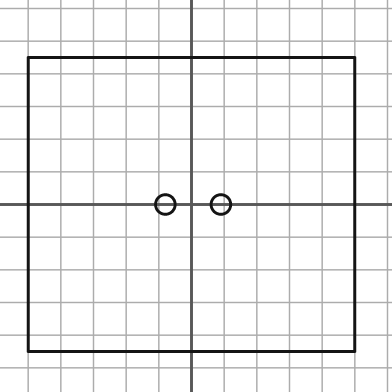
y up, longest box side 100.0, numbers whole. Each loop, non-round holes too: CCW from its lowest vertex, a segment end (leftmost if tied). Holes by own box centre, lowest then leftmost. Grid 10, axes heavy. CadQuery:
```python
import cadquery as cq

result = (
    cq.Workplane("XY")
    .moveTo(-50.0, -45.0)
    .lineTo(50.0, -45.0)
    .lineTo(50.0, 45.0)
    .lineTo(-50.0, 45.0)
    .close()
    .moveTo(-8.0, 0.0)
    .circle(3.0)
    .moveTo(9.0, 0.0)
    .circle(3.0)
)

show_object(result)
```